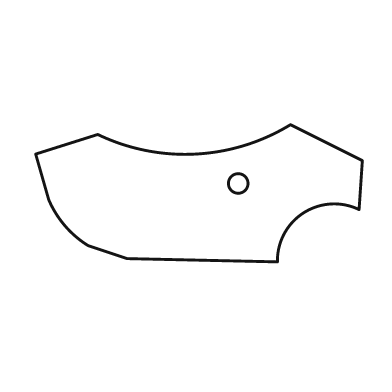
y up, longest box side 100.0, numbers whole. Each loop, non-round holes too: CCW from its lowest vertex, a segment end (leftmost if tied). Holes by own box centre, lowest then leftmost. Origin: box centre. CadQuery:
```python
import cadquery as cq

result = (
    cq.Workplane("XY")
    .moveTo(24.0, -21.0)
    .threePointArc((32.0, -6.0), (49.0, -5.0))
    .lineTo(50.0, 10.0)
    .lineTo(28.0, 21.0)
    .threePointArc((-1.0, 12.0), (-31.0, 18.0))
    .lineTo(-50.0, 12.0)
    .lineTo(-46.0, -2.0)
    .threePointArc((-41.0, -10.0), (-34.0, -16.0))
    .lineTo(-22.0, -20.0)
    .close()
    .moveTo(12.0, 3.0)
    .circle(3.0)
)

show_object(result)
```